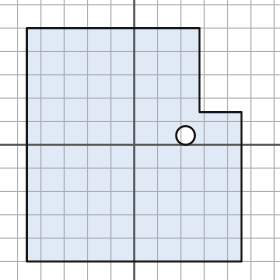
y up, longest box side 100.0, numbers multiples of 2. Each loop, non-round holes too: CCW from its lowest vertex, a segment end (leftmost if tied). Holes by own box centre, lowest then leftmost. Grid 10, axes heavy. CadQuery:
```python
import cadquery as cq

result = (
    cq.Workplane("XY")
    .moveTo(-46.0, -50.0)
    .lineTo(46.0, -50.0)
    .lineTo(46.0, 14.0)
    .lineTo(28.0, 14.0)
    .lineTo(28.0, 50.0)
    .lineTo(-46.0, 50.0)
    .close()
    .moveTo(22.0, 4.0)
    .circle(4.0)
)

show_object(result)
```